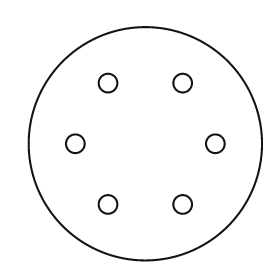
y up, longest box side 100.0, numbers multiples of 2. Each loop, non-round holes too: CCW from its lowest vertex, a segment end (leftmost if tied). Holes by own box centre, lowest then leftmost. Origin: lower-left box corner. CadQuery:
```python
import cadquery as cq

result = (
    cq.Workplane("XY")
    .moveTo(50.0, 50.0)
    .circle(50.0)
    .moveTo(34.0, 24.0)
    .circle(4.0)
    .moveTo(66.0, 24.0)
    .circle(4.0)
    .moveTo(20.0, 50.0)
    .circle(4.0)
    .moveTo(80.0, 50.0)
    .circle(4.0)
    .moveTo(34.0, 76.0)
    .circle(4.0)
    .moveTo(66.0, 76.0)
    .circle(4.0)
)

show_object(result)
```